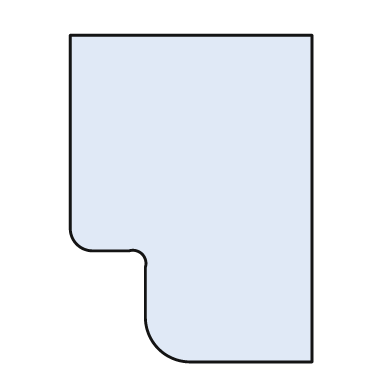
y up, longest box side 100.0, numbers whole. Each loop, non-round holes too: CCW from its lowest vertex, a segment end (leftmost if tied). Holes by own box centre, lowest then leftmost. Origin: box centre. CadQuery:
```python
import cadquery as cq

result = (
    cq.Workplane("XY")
    .moveTo(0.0, -50.0)
    .lineTo(37.0, -50.0)
    .lineTo(37.0, 50.0)
    .lineTo(-37.0, 50.0)
    .lineTo(-37.0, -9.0)
    .threePointArc((-35.0, -14.0), (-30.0, -16.0))
    .lineTo(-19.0, -16.0)
    .threePointArc((-15.0, -17.0), (-14.0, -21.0))
    .lineTo(-14.0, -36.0)
    .threePointArc((-10.0, -46.0), (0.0, -50.0))
    .close()
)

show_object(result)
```